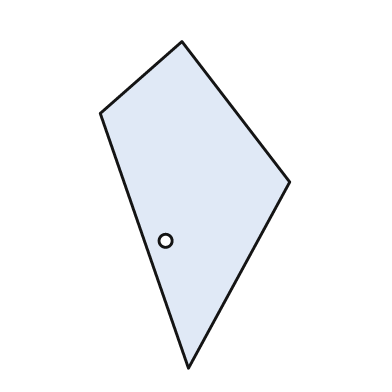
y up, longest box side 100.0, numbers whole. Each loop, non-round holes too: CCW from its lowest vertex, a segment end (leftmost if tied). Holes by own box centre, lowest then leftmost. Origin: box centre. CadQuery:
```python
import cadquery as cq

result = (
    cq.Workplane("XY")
    .moveTo(-2.0, -50.0)
    .lineTo(29.0, 7.0)
    .lineTo(-4.0, 50.0)
    .lineTo(-29.0, 28.0)
    .close()
    .moveTo(-9.0, -11.0)
    .circle(2.0)
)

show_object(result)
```